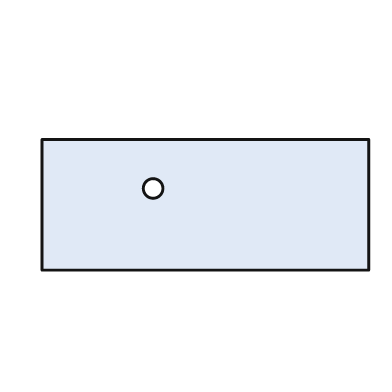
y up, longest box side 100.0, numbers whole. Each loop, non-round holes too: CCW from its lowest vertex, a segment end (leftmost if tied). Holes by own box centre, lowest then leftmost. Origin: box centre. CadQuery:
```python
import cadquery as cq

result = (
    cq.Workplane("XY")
    .moveTo(-50.0, -20.0)
    .lineTo(50.0, -20.0)
    .lineTo(50.0, 20.0)
    .lineTo(-50.0, 20.0)
    .close()
    .moveTo(-16.0, 5.0)
    .circle(3.0)
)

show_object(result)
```